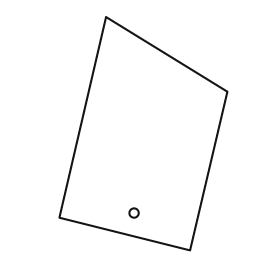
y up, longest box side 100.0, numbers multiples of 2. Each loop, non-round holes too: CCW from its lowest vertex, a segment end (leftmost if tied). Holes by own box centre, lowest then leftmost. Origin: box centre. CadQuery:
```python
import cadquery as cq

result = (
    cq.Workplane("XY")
    .moveTo(20.0, -50.0)
    .lineTo(36.0, 18.0)
    .lineTo(-16.0, 50.0)
    .lineTo(-36.0, -36.0)
    .close()
    .moveTo(-4.0, -34.0)
    .circle(2.0)
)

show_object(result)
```